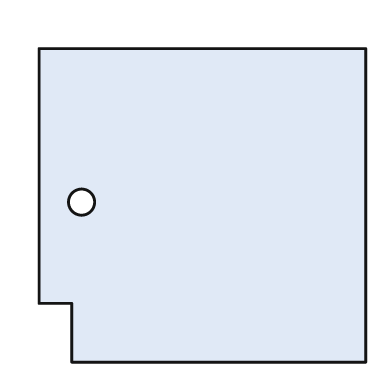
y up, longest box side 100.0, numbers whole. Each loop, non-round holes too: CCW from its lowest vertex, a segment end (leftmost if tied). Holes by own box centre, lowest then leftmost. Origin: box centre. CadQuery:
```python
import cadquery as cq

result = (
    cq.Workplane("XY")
    .moveTo(-40.0, -48.0)
    .lineTo(50.0, -48.0)
    .lineTo(50.0, 48.0)
    .lineTo(-50.0, 48.0)
    .lineTo(-50.0, -30.0)
    .lineTo(-40.0, -30.0)
    .close()
    .moveTo(-37.0, 1.0)
    .circle(4.0)
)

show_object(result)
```